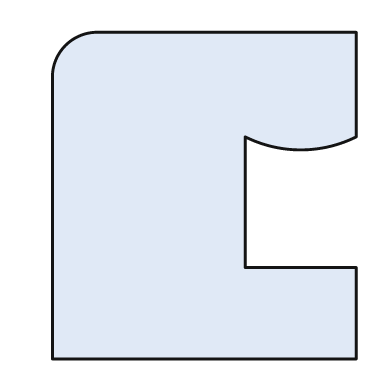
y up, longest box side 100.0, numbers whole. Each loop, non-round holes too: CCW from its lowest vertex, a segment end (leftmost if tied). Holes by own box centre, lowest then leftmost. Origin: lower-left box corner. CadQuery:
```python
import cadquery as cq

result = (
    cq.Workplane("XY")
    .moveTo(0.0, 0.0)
    .lineTo(93.0, 0.0)
    .lineTo(93.0, 28.0)
    .lineTo(59.0, 28.0)
    .lineTo(59.0, 68.0)
    .threePointArc((76.0, 64.0), (93.0, 68.0))
    .lineTo(93.0, 100.0)
    .lineTo(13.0, 100.0)
    .threePointArc((4.0, 96.0), (0.0, 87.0))
    .close()
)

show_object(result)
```